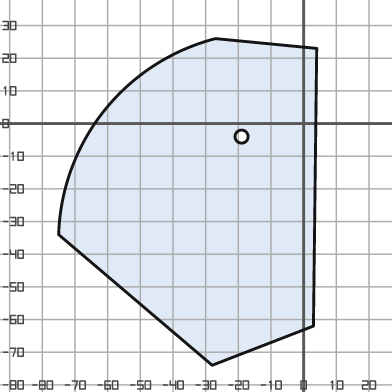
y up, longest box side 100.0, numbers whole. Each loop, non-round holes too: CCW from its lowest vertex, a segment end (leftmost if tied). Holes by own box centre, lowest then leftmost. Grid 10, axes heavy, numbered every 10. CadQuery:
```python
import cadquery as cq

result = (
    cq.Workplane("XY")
    .moveTo(-28.0, -74.0)
    .lineTo(3.0, -62.0)
    .lineTo(4.0, 23.0)
    .lineTo(-27.0, 26.0)
    .threePointArc((-61.0, 4.0), (-75.0, -34.0))
    .close()
    .moveTo(-19.0, -4.0)
    .circle(2.0)
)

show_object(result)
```